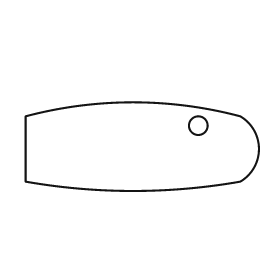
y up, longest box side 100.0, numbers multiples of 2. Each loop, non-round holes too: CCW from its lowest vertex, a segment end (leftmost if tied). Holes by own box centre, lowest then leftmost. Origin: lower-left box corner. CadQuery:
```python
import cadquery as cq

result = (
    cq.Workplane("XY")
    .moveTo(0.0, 4.0)
    .threePointArc((46.0, 0.0), (92.0, 4.0))
    .threePointArc((100.0, 18.0), (92.0, 32.0))
    .threePointArc((46.0, 38.0), (0.0, 32.0))
    .close()
    .moveTo(74.0, 28.0)
    .circle(4.0)
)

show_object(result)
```